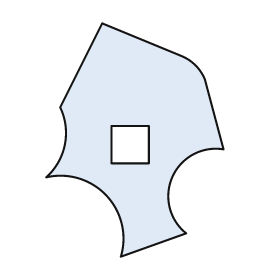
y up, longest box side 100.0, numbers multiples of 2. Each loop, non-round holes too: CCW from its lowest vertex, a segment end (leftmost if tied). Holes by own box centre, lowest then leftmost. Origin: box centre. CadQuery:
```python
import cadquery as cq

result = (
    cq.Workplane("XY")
    .moveTo(-6.0, -50.0)
    .lineTo(22.0, -40.0)
    .threePointArc((16.0, -16.0), (38.0, -4.0))
    .lineTo(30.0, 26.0)
    .threePointArc((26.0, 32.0), (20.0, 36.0))
    .lineTo(-14.0, 50.0)
    .lineTo(-32.0, 14.0)
    .threePointArc((-30.0, -2.0), (-38.0, -16.0))
    .threePointArc((-12.0, -24.0), (-6.0, -50.0))
    .close()
    .moveTo(-10.0, -10.0)
    .lineTo(6.0, -10.0)
    .lineTo(6.0, 6.0)
    .lineTo(-10.0, 6.0)
    .close()
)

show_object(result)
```